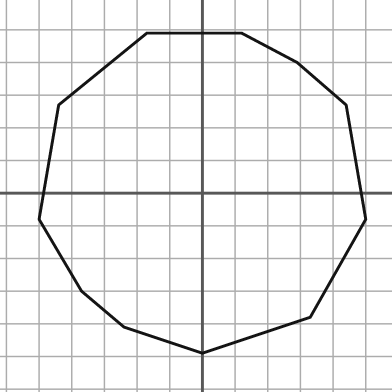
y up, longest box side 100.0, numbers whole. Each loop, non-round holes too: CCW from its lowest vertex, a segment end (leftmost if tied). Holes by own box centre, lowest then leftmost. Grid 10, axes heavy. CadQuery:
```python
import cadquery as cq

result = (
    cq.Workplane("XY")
    .moveTo(0.0, -49.0)
    .lineTo(33.0, -38.0)
    .lineTo(50.0, -8.0)
    .lineTo(44.0, 27.0)
    .lineTo(29.0, 40.0)
    .lineTo(12.0, 49.0)
    .lineTo(-17.0, 49.0)
    .lineTo(-44.0, 27.0)
    .lineTo(-50.0, -8.0)
    .lineTo(-37.0, -30.0)
    .lineTo(-24.0, -41.0)
    .close()
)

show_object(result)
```